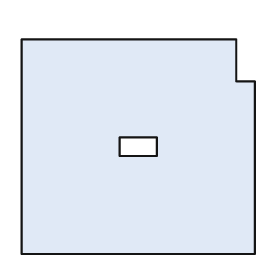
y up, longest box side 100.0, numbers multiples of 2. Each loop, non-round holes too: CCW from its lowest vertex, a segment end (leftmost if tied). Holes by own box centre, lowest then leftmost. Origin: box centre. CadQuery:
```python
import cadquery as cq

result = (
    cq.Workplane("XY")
    .moveTo(-50.0, -46.0)
    .lineTo(50.0, -46.0)
    .lineTo(50.0, 28.0)
    .lineTo(42.0, 28.0)
    .lineTo(42.0, 46.0)
    .lineTo(-50.0, 46.0)
    .close()
    .moveTo(-8.0, -4.0)
    .lineTo(8.0, -4.0)
    .lineTo(8.0, 4.0)
    .lineTo(-8.0, 4.0)
    .close()
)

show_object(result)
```